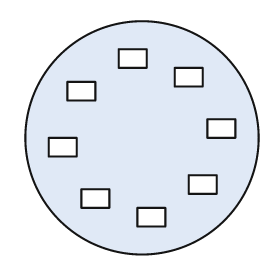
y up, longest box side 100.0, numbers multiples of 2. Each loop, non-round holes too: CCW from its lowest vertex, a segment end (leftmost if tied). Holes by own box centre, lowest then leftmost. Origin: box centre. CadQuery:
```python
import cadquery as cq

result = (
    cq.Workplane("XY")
    .moveTo(0.0, 0.0)
    .circle(50.0)
    .moveTo(-2.0, -38.0)
    .lineTo(10.0, -38.0)
    .lineTo(10.0, -30.0)
    .lineTo(-2.0, -30.0)
    .close()
    .moveTo(-26.0, -30.0)
    .lineTo(-14.0, -30.0)
    .lineTo(-14.0, -22.0)
    .lineTo(-26.0, -22.0)
    .close()
    .moveTo(20.0, -24.0)
    .lineTo(32.0, -24.0)
    .lineTo(32.0, -16.0)
    .lineTo(20.0, -16.0)
    .close()
    .moveTo(-40.0, -8.0)
    .lineTo(-28.0, -8.0)
    .lineTo(-28.0, 0.0)
    .lineTo(-40.0, 0.0)
    .close()
    .moveTo(28.0, 0.0)
    .lineTo(40.0, 0.0)
    .lineTo(40.0, 8.0)
    .lineTo(28.0, 8.0)
    .close()
    .moveTo(-32.0, 16.0)
    .lineTo(-20.0, 16.0)
    .lineTo(-20.0, 24.0)
    .lineTo(-32.0, 24.0)
    .close()
    .moveTo(14.0, 22.0)
    .lineTo(26.0, 22.0)
    .lineTo(26.0, 30.0)
    .lineTo(14.0, 30.0)
    .close()
    .moveTo(-10.0, 30.0)
    .lineTo(2.0, 30.0)
    .lineTo(2.0, 38.0)
    .lineTo(-10.0, 38.0)
    .close()
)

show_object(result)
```